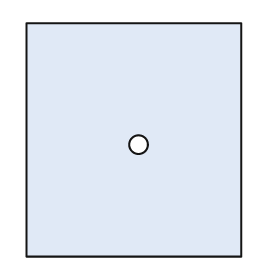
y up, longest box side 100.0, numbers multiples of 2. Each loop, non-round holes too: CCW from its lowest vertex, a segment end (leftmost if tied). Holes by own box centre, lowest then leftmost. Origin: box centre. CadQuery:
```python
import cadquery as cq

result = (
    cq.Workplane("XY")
    .moveTo(-46.0, -50.0)
    .lineTo(46.0, -50.0)
    .lineTo(46.0, 50.0)
    .lineTo(-46.0, 50.0)
    .close()
    .moveTo(2.0, -2.0)
    .circle(4.0)
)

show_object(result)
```